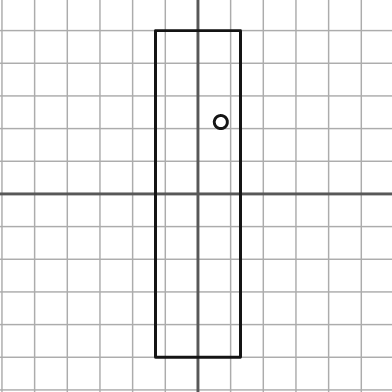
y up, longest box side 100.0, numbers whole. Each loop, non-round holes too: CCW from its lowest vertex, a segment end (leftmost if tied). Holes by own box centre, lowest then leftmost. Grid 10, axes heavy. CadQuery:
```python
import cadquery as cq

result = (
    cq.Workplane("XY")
    .moveTo(-13.0, -50.0)
    .lineTo(13.0, -50.0)
    .lineTo(13.0, 50.0)
    .lineTo(-13.0, 50.0)
    .close()
    .moveTo(7.0, 22.0)
    .circle(2.0)
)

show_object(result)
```